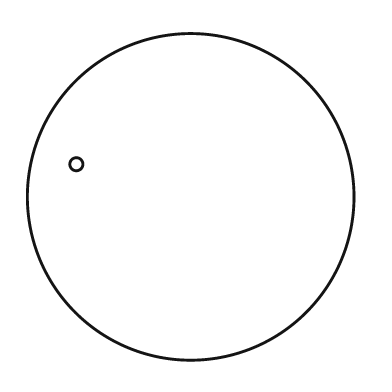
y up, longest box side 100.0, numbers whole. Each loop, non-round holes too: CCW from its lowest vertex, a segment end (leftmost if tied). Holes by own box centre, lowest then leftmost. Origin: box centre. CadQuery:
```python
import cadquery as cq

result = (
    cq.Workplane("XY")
    .moveTo(0.0, 0.0)
    .circle(50.0)
    .moveTo(-35.0, 10.0)
    .circle(2.0)
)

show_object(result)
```